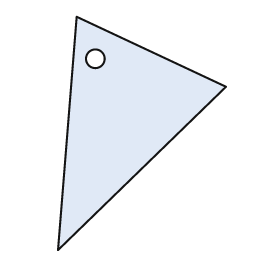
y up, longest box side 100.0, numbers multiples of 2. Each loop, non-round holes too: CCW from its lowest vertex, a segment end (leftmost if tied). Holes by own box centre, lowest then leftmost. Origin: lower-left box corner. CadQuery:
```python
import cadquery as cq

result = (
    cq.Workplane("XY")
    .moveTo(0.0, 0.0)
    .lineTo(72.0, 70.0)
    .lineTo(8.0, 100.0)
    .close()
    .moveTo(16.0, 82.0)
    .circle(4.0)
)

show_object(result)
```